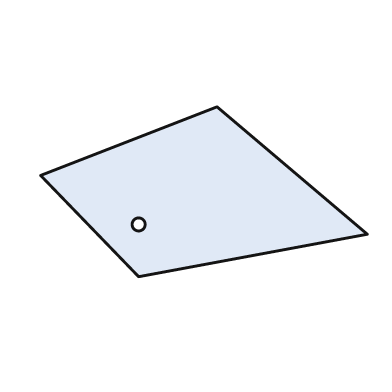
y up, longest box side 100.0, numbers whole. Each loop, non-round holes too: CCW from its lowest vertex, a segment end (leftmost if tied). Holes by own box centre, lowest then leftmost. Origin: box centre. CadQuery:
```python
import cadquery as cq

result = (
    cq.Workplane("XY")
    .moveTo(-20.0, -26.0)
    .lineTo(50.0, -13.0)
    .lineTo(4.0, 26.0)
    .lineTo(-50.0, 5.0)
    .close()
    .moveTo(-20.0, -10.0)
    .circle(2.0)
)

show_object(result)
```